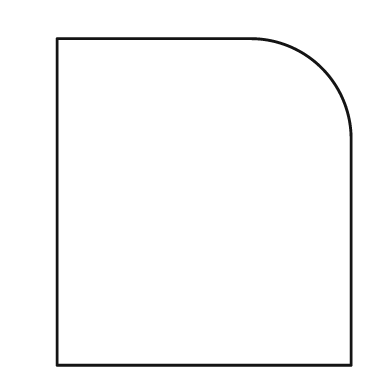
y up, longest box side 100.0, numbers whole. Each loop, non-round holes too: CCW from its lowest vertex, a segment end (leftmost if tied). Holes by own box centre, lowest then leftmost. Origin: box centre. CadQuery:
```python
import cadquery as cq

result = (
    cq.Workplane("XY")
    .moveTo(-45.0, -50.0)
    .lineTo(45.0, -50.0)
    .lineTo(45.0, 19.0)
    .threePointArc((36.0, 41.0), (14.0, 50.0))
    .lineTo(-45.0, 50.0)
    .close()
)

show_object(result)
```